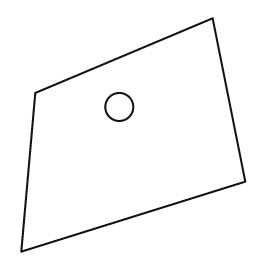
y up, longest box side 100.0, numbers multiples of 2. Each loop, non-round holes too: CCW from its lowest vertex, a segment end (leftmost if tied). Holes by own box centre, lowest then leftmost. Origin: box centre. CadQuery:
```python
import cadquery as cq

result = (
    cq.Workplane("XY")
    .moveTo(-48.0, -50.0)
    .lineTo(48.0, -20.0)
    .lineTo(34.0, 50.0)
    .lineTo(-42.0, 18.0)
    .close()
    .moveTo(-6.0, 12.0)
    .circle(6.0)
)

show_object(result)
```